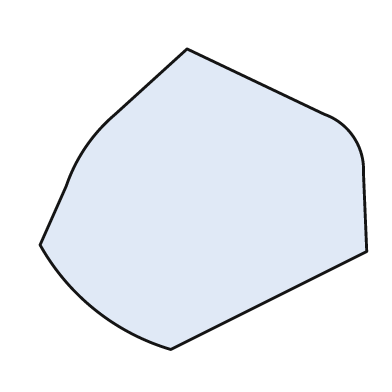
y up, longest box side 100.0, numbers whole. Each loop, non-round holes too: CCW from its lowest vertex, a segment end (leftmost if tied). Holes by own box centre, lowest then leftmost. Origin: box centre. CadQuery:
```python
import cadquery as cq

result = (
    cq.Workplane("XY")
    .moveTo(-10.0, -46.0)
    .lineTo(50.0, -16.0)
    .lineTo(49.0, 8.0)
    .threePointArc((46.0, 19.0), (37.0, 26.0))
    .lineTo(-5.0, 46.0)
    .lineTo(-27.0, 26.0)
    .threePointArc((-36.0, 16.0), (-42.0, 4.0))
    .lineTo(-50.0, -14.0)
    .threePointArc((-33.0, -34.0), (-10.0, -46.0))
    .close()
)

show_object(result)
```